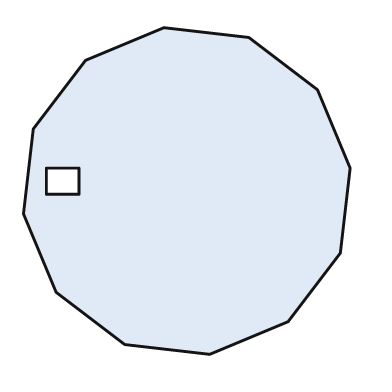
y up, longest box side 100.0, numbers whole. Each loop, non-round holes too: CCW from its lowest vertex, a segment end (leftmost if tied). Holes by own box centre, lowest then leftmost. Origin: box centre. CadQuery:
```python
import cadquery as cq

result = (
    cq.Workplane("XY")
    .moveTo(7.0, -50.0)
    .lineTo(31.0, -40.0)
    .lineTo(47.0, -19.0)
    .lineTo(50.0, 7.0)
    .lineTo(40.0, 31.0)
    .lineTo(19.0, 47.0)
    .lineTo(-7.0, 50.0)
    .lineTo(-31.0, 40.0)
    .lineTo(-47.0, 19.0)
    .lineTo(-50.0, -7.0)
    .lineTo(-40.0, -31.0)
    .lineTo(-19.0, -47.0)
    .close()
    .moveTo(-43.0, -1.0)
    .lineTo(-33.0, -1.0)
    .lineTo(-33.0, 7.0)
    .lineTo(-43.0, 7.0)
    .close()
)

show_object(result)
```